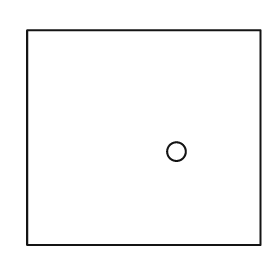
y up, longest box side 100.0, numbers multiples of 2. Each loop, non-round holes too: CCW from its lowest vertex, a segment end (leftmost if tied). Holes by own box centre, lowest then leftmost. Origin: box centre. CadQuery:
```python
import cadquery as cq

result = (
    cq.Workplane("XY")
    .moveTo(-50.0, -46.0)
    .lineTo(50.0, -46.0)
    .lineTo(50.0, 46.0)
    .lineTo(-50.0, 46.0)
    .close()
    .moveTo(14.0, -6.0)
    .circle(4.0)
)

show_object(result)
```